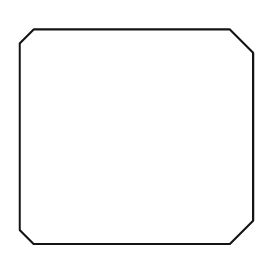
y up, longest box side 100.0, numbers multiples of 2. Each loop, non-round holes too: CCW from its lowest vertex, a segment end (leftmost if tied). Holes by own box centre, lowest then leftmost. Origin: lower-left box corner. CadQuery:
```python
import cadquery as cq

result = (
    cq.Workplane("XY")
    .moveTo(6.0, 0.0)
    .lineTo(90.0, 0.0)
    .lineTo(100.0, 10.0)
    .lineTo(100.0, 82.0)
    .lineTo(90.0, 92.0)
    .lineTo(6.0, 92.0)
    .lineTo(0.0, 86.0)
    .lineTo(0.0, 6.0)
    .close()
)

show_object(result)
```